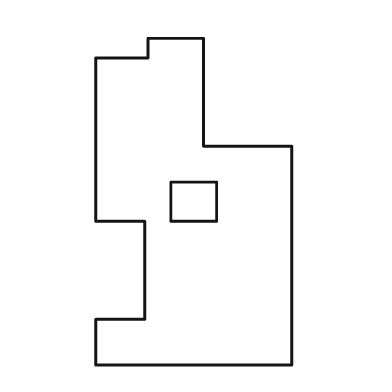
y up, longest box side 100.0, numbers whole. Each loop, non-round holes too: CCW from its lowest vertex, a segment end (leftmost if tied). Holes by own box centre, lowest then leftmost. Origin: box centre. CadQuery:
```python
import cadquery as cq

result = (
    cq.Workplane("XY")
    .moveTo(-30.0, -50.0)
    .lineTo(30.0, -50.0)
    .lineTo(30.0, 17.0)
    .lineTo(3.0, 17.0)
    .lineTo(3.0, 50.0)
    .lineTo(-14.0, 50.0)
    .lineTo(-14.0, 44.0)
    .lineTo(-30.0, 44.0)
    .lineTo(-30.0, -6.0)
    .lineTo(-15.0, -6.0)
    .lineTo(-15.0, -36.0)
    .lineTo(-30.0, -36.0)
    .close()
    .moveTo(-7.0, -6.0)
    .lineTo(7.0, -6.0)
    .lineTo(7.0, 6.0)
    .lineTo(-7.0, 6.0)
    .close()
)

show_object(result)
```